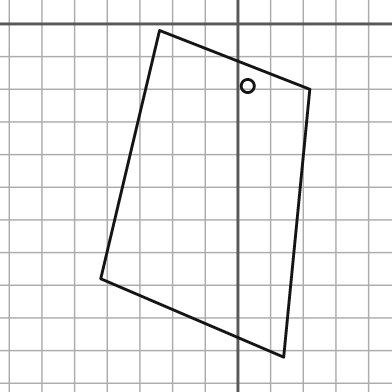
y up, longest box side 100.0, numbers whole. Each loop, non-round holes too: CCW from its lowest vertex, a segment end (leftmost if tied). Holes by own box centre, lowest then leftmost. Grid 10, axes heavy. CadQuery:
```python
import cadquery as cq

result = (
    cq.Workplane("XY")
    .moveTo(14.0, -102.0)
    .lineTo(22.0, -20.0)
    .lineTo(-24.0, -2.0)
    .lineTo(-42.0, -78.0)
    .close()
    .moveTo(3.0, -19.0)
    .circle(2.0)
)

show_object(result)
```